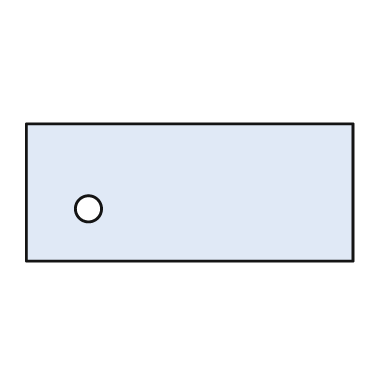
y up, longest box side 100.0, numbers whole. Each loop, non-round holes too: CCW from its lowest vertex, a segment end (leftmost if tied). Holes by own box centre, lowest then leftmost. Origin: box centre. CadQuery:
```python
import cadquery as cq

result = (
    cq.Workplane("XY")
    .moveTo(-50.0, -21.0)
    .lineTo(50.0, -21.0)
    .lineTo(50.0, 21.0)
    .lineTo(-50.0, 21.0)
    .close()
    .moveTo(-31.0, -5.0)
    .circle(4.0)
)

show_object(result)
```